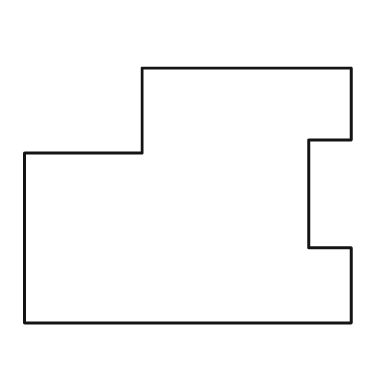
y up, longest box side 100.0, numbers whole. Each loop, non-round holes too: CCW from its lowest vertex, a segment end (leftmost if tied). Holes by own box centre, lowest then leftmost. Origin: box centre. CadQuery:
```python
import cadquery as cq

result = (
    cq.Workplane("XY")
    .moveTo(-50.0, -39.0)
    .lineTo(50.0, -39.0)
    .lineTo(50.0, -16.0)
    .lineTo(37.0, -16.0)
    .lineTo(37.0, 17.0)
    .lineTo(50.0, 17.0)
    .lineTo(50.0, 39.0)
    .lineTo(-14.0, 39.0)
    .lineTo(-14.0, 13.0)
    .lineTo(-50.0, 13.0)
    .close()
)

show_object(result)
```